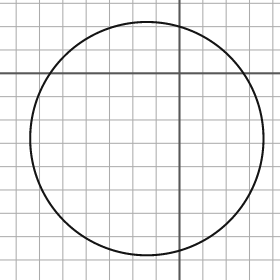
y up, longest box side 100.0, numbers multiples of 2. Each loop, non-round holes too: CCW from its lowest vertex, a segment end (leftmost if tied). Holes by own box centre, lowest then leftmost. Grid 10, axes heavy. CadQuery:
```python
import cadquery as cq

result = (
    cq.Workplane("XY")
    .moveTo(-14.0, -28.0)
    .circle(50.0)
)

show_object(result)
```